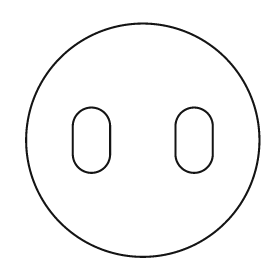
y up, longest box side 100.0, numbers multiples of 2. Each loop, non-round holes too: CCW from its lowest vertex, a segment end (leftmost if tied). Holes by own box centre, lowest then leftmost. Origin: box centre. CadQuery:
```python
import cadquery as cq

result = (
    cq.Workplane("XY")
    .moveTo(0.0, 0.0)
    .circle(50.0)
    .moveTo(-30.0, -6.0)
    .threePointArc((-22.0, -14.0), (-14.0, -6.0))
    .lineTo(-14.0, 6.0)
    .threePointArc((-22.0, 14.0), (-30.0, 6.0))
    .close()
    .moveTo(14.0, -6.0)
    .threePointArc((22.0, -14.0), (30.0, -6.0))
    .lineTo(30.0, 6.0)
    .threePointArc((22.0, 14.0), (14.0, 6.0))
    .close()
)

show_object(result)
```